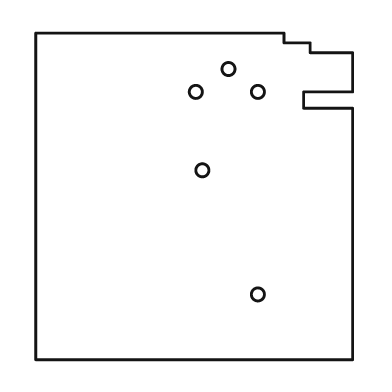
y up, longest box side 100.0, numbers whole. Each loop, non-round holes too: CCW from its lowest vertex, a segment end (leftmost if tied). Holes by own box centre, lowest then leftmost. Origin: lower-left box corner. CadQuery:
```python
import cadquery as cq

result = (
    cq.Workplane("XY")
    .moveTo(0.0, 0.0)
    .lineTo(97.0, 0.0)
    .lineTo(97.0, 77.0)
    .lineTo(82.0, 77.0)
    .lineTo(82.0, 82.0)
    .lineTo(97.0, 82.0)
    .lineTo(97.0, 94.0)
    .lineTo(84.0, 94.0)
    .lineTo(84.0, 97.0)
    .lineTo(76.0, 97.0)
    .lineTo(76.0, 100.0)
    .lineTo(0.0, 100.0)
    .close()
    .moveTo(68.0, 20.0)
    .circle(2.0)
    .moveTo(51.0, 58.0)
    .circle(2.0)
    .moveTo(49.0, 82.0)
    .circle(2.0)
    .moveTo(68.0, 82.0)
    .circle(2.0)
    .moveTo(59.0, 89.0)
    .circle(2.0)
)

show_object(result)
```